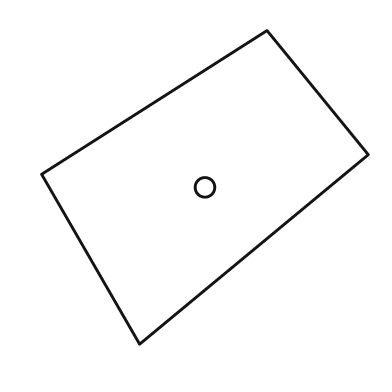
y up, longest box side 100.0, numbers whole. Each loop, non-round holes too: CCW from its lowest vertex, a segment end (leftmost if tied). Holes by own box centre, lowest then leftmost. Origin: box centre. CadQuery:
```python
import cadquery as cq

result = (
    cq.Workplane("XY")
    .moveTo(-20.0, -48.0)
    .lineTo(50.0, 10.0)
    .lineTo(19.0, 48.0)
    .lineTo(-50.0, 4.0)
    .close()
    .moveTo(0.0, 0.0)
    .circle(3.0)
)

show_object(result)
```